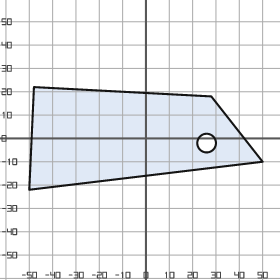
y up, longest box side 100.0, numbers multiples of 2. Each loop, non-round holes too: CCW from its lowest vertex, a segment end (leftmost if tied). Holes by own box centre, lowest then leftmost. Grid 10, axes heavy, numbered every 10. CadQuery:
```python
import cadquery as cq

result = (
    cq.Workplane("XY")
    .moveTo(-50.0, -22.0)
    .lineTo(50.0, -10.0)
    .lineTo(28.0, 18.0)
    .lineTo(-48.0, 22.0)
    .close()
    .moveTo(26.0, -2.0)
    .circle(4.0)
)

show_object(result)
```